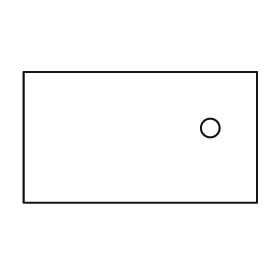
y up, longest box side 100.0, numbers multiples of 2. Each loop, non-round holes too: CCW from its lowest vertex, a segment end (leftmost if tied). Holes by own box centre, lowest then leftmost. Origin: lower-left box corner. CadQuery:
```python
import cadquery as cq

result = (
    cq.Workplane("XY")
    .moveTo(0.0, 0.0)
    .lineTo(100.0, 0.0)
    .lineTo(100.0, 56.0)
    .lineTo(0.0, 56.0)
    .close()
    .moveTo(80.0, 32.0)
    .circle(4.0)
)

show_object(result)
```